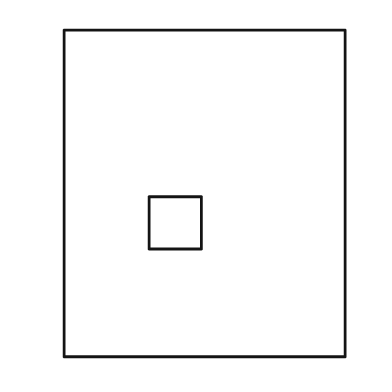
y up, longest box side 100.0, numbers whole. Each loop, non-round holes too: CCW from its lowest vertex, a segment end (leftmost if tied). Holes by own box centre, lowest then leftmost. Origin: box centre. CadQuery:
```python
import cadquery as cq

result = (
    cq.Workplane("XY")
    .moveTo(-43.0, -50.0)
    .lineTo(43.0, -50.0)
    .lineTo(43.0, 50.0)
    .lineTo(-43.0, 50.0)
    .close()
    .moveTo(-17.0, -17.0)
    .lineTo(-1.0, -17.0)
    .lineTo(-1.0, -1.0)
    .lineTo(-17.0, -1.0)
    .close()
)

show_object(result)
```